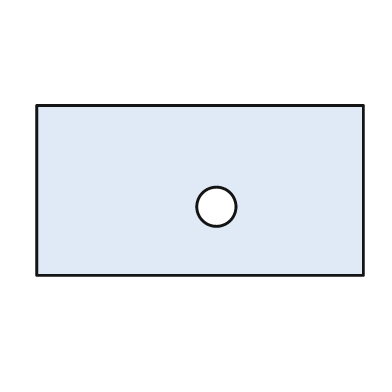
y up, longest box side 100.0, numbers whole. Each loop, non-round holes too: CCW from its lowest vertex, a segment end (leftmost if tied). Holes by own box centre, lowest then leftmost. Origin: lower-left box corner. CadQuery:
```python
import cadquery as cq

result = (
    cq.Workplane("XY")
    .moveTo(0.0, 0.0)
    .lineTo(100.0, 0.0)
    .lineTo(100.0, 52.0)
    .lineTo(0.0, 52.0)
    .close()
    .moveTo(55.0, 21.0)
    .circle(6.0)
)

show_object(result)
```